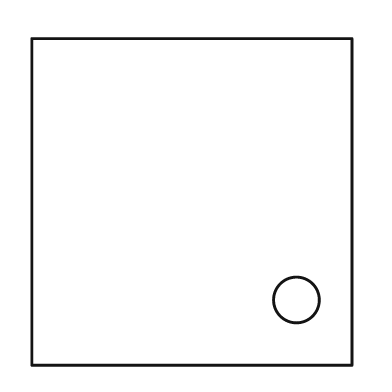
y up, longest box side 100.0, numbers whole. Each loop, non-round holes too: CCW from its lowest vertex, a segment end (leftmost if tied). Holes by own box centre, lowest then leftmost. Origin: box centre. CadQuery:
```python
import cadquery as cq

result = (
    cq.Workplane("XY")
    .moveTo(-49.0, -50.0)
    .lineTo(49.0, -50.0)
    .lineTo(49.0, 50.0)
    .lineTo(-49.0, 50.0)
    .close()
    .moveTo(32.0, -30.0)
    .circle(7.0)
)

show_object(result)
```